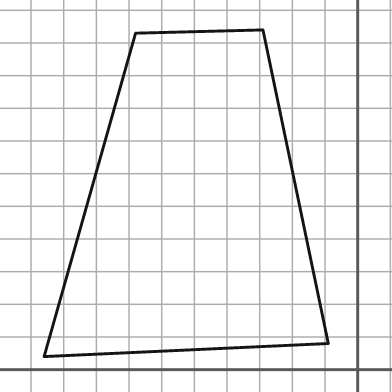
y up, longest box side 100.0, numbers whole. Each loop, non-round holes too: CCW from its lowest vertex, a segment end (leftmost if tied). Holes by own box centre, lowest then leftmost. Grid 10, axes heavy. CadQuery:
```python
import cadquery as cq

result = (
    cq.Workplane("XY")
    .moveTo(-96.0, 4.0)
    .lineTo(-9.0, 8.0)
    .lineTo(-29.0, 104.0)
    .lineTo(-68.0, 103.0)
    .close()
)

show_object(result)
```